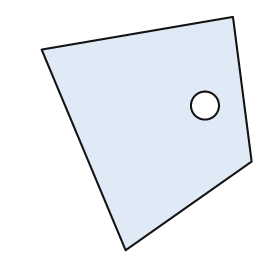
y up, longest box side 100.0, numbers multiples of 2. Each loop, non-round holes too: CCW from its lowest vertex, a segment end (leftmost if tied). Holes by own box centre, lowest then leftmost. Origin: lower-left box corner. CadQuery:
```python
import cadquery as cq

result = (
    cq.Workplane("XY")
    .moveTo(36.0, 0.0)
    .lineTo(90.0, 38.0)
    .lineTo(82.0, 100.0)
    .lineTo(0.0, 86.0)
    .close()
    .moveTo(70.0, 62.0)
    .circle(6.0)
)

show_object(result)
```